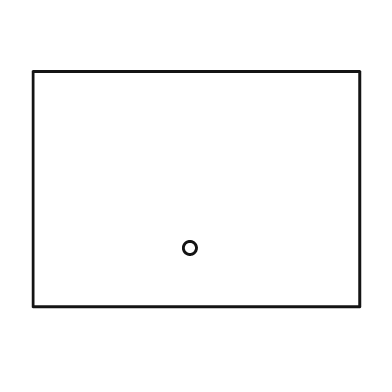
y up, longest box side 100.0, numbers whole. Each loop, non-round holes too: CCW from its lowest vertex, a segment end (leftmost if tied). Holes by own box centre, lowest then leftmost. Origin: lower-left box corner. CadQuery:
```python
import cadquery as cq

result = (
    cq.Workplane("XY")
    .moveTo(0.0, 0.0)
    .lineTo(100.0, 0.0)
    .lineTo(100.0, 72.0)
    .lineTo(0.0, 72.0)
    .close()
    .moveTo(48.0, 18.0)
    .circle(2.0)
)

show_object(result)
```